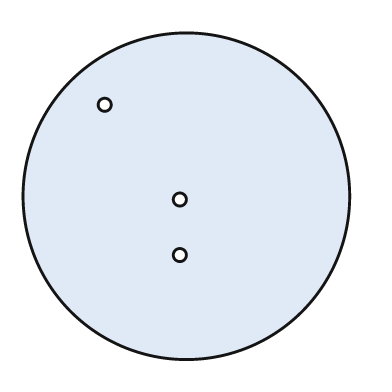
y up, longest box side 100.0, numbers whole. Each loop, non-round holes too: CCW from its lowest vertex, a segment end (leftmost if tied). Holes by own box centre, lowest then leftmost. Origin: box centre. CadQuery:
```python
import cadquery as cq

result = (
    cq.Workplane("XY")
    .moveTo(0.0, 0.0)
    .circle(50.0)
    .moveTo(-2.0, -18.0)
    .circle(2.0)
    .moveTo(-2.0, -1.0)
    .circle(2.0)
    .moveTo(-25.0, 28.0)
    .circle(2.0)
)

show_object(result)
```